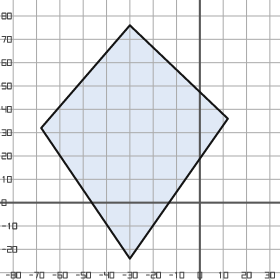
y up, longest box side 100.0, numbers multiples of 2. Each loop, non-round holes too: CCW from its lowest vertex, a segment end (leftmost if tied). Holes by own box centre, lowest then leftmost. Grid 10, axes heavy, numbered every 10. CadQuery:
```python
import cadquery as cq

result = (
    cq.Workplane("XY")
    .moveTo(-30.0, -24.0)
    .lineTo(12.0, 36.0)
    .lineTo(-30.0, 76.0)
    .lineTo(-68.0, 32.0)
    .close()
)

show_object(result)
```